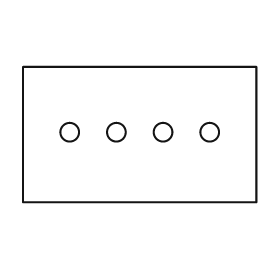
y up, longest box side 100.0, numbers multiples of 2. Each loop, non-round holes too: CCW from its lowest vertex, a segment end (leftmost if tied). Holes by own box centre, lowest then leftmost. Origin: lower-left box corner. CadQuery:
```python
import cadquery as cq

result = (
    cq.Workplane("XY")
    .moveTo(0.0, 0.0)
    .lineTo(100.0, 0.0)
    .lineTo(100.0, 58.0)
    .lineTo(0.0, 58.0)
    .close()
    .moveTo(20.0, 30.0)
    .circle(4.0)
    .moveTo(40.0, 30.0)
    .circle(4.0)
    .moveTo(60.0, 30.0)
    .circle(4.0)
    .moveTo(80.0, 30.0)
    .circle(4.0)
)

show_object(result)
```